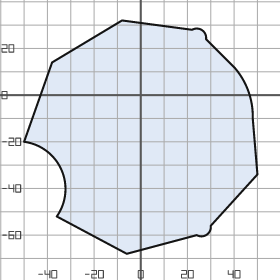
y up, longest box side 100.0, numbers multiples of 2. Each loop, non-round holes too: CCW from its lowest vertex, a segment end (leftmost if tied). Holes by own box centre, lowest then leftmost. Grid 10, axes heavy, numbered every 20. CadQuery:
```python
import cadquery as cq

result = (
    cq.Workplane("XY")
    .moveTo(-6.0, -68.0)
    .lineTo(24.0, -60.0)
    .threePointArc((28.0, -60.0), (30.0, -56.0))
    .lineTo(50.0, -34.0)
    .lineTo(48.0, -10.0)
    .threePointArc((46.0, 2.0), (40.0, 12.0))
    .lineTo(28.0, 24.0)
    .threePointArc((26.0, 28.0), (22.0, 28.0))
    .lineTo(-8.0, 32.0)
    .lineTo(-38.0, 14.0)
    .lineTo(-50.0, -20.0)
    .threePointArc((-34.0, -32.0), (-36.0, -52.0))
    .close()
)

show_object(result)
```